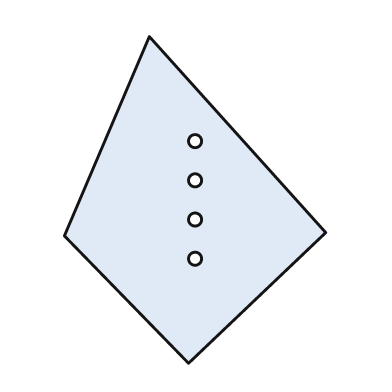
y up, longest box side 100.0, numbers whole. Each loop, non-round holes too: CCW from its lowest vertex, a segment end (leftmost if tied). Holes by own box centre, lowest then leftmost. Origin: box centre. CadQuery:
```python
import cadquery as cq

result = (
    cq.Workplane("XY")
    .moveTo(-2.0, -50.0)
    .lineTo(40.0, -10.0)
    .lineTo(-14.0, 50.0)
    .lineTo(-40.0, -11.0)
    .close()
    .moveTo(0.0, -18.0)
    .circle(2.0)
    .moveTo(0.0, -6.0)
    .circle(2.0)
    .moveTo(0.0, 6.0)
    .circle(2.0)
    .moveTo(0.0, 18.0)
    .circle(2.0)
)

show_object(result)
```